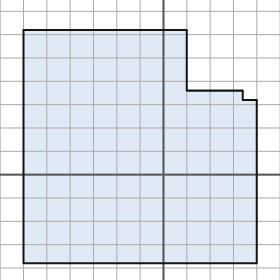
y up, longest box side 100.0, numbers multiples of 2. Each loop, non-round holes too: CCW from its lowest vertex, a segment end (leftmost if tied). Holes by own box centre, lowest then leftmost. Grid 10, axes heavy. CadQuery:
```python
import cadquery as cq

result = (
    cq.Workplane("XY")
    .moveTo(-60.0, -38.0)
    .lineTo(40.0, -38.0)
    .lineTo(40.0, 32.0)
    .lineTo(34.0, 32.0)
    .lineTo(34.0, 36.0)
    .lineTo(10.0, 36.0)
    .lineTo(10.0, 62.0)
    .lineTo(-60.0, 62.0)
    .close()
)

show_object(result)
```